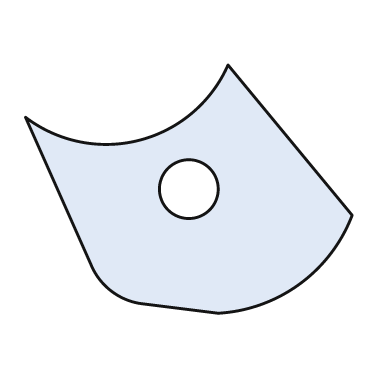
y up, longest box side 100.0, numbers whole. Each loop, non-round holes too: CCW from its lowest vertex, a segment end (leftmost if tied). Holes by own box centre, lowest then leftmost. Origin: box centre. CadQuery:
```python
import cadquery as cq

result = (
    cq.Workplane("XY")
    .moveTo(9.0, -38.0)
    .threePointArc((34.0, -29.0), (50.0, -8.0))
    .lineTo(12.0, 38.0)
    .threePointArc((-15.0, 15.0), (-50.0, 22.0))
    .lineTo(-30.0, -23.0)
    .threePointArc((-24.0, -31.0), (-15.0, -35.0))
    .close()
    .moveTo(0.0, 0.0)
    .circle(9.0)
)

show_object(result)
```